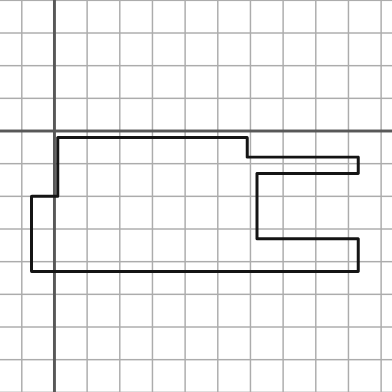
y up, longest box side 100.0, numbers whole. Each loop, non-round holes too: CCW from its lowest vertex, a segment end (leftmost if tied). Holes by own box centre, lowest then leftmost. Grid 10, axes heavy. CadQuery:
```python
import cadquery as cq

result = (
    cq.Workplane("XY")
    .moveTo(-7.0, -43.0)
    .lineTo(93.0, -43.0)
    .lineTo(93.0, -33.0)
    .lineTo(62.0, -33.0)
    .lineTo(62.0, -13.0)
    .lineTo(93.0, -13.0)
    .lineTo(93.0, -8.0)
    .lineTo(59.0, -8.0)
    .lineTo(59.0, -2.0)
    .lineTo(1.0, -2.0)
    .lineTo(1.0, -20.0)
    .lineTo(-7.0, -20.0)
    .close()
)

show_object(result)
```